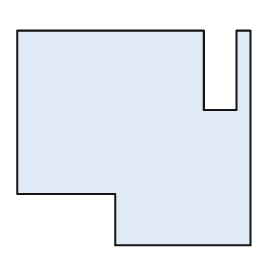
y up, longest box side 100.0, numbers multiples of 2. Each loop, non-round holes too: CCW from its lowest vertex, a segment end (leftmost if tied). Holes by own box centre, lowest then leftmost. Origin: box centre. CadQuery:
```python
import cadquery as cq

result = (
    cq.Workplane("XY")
    .moveTo(-8.0, -46.0)
    .lineTo(50.0, -46.0)
    .lineTo(50.0, 46.0)
    .lineTo(44.0, 46.0)
    .lineTo(44.0, 12.0)
    .lineTo(30.0, 12.0)
    .lineTo(30.0, 46.0)
    .lineTo(-50.0, 46.0)
    .lineTo(-50.0, -24.0)
    .lineTo(-8.0, -24.0)
    .close()
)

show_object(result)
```